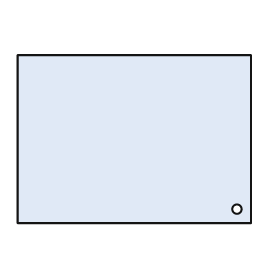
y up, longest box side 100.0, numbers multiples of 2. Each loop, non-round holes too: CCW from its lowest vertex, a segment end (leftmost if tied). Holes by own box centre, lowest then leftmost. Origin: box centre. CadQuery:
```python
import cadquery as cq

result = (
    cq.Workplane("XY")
    .moveTo(-50.0, -36.0)
    .lineTo(50.0, -36.0)
    .lineTo(50.0, 36.0)
    .lineTo(-50.0, 36.0)
    .close()
    .moveTo(44.0, -30.0)
    .circle(2.0)
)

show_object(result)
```